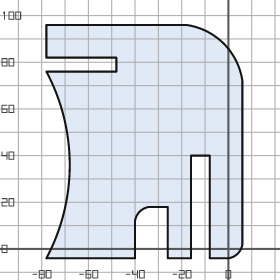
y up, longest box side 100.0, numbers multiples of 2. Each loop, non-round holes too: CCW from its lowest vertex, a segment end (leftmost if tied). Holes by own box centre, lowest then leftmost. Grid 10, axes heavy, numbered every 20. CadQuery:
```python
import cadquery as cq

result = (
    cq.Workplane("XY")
    .moveTo(-78.0, -4.0)
    .lineTo(-40.0, -4.0)
    .lineTo(-40.0, 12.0)
    .threePointArc((-38.0, 16.0), (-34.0, 18.0))
    .lineTo(-26.0, 18.0)
    .lineTo(-26.0, -4.0)
    .lineTo(-16.0, -4.0)
    .lineTo(-16.0, 40.0)
    .lineTo(-8.0, 40.0)
    .lineTo(-8.0, -4.0)
    .lineTo(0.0, -4.0)
    .threePointArc((4.0, -2.0), (6.0, 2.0))
    .lineTo(6.0, 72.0)
    .threePointArc((-2.0, 88.0), (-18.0, 96.0))
    .lineTo(-78.0, 96.0)
    .lineTo(-78.0, 82.0)
    .lineTo(-48.0, 82.0)
    .lineTo(-48.0, 76.0)
    .lineTo(-78.0, 76.0)
    .threePointArc((-68.0, 36.0), (-78.0, -4.0))
    .close()
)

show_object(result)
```